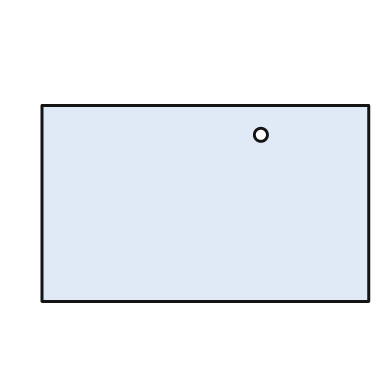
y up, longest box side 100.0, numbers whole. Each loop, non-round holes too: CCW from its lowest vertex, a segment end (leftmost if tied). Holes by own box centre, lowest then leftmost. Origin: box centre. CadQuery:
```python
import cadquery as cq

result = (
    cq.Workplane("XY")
    .moveTo(-50.0, -30.0)
    .lineTo(50.0, -30.0)
    .lineTo(50.0, 30.0)
    .lineTo(-50.0, 30.0)
    .close()
    .moveTo(17.0, 21.0)
    .circle(2.0)
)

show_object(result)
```